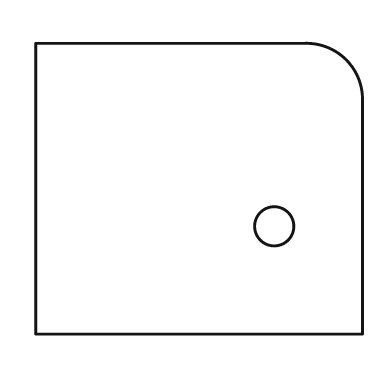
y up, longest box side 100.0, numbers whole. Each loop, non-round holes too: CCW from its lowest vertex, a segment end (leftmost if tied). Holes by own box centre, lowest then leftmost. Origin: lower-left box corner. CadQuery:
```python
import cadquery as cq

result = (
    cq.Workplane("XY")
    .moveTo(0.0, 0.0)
    .lineTo(100.0, 0.0)
    .lineTo(100.0, 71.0)
    .threePointArc((95.0, 84.0), (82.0, 89.0))
    .lineTo(0.0, 89.0)
    .close()
    .moveTo(73.0, 33.0)
    .circle(6.0)
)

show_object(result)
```